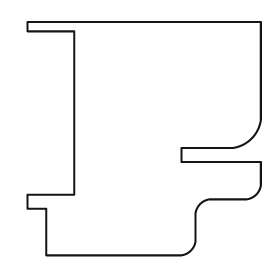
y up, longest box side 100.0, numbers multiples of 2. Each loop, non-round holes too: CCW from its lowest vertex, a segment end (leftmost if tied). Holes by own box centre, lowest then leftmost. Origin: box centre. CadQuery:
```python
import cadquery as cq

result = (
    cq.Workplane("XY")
    .moveTo(-42.0, -50.0)
    .lineTo(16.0, -50.0)
    .threePointArc((20.0, -48.0), (22.0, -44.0))
    .lineTo(22.0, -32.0)
    .threePointArc((24.0, -28.0), (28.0, -26.0))
    .lineTo(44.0, -26.0)
    .threePointArc((48.0, -24.0), (50.0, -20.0))
    .lineTo(50.0, -10.0)
    .lineTo(16.0, -10.0)
    .lineTo(16.0, -4.0)
    .lineTo(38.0, -4.0)
    .threePointArc((46.0, 0.0), (50.0, 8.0))
    .lineTo(50.0, 50.0)
    .lineTo(-50.0, 50.0)
    .lineTo(-50.0, 46.0)
    .lineTo(-30.0, 46.0)
    .lineTo(-30.0, -24.0)
    .lineTo(-50.0, -24.0)
    .lineTo(-50.0, -30.0)
    .lineTo(-42.0, -30.0)
    .close()
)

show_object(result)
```